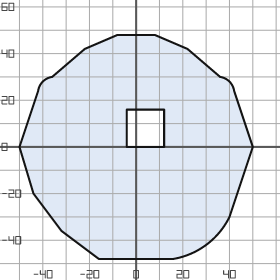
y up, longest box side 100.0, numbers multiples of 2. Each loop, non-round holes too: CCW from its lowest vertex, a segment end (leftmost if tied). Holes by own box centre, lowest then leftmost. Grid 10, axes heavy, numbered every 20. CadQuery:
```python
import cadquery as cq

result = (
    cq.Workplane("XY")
    .moveTo(-16.0, -48.0)
    .lineTo(16.0, -48.0)
    .threePointArc((30.0, -42.0), (40.0, -30.0))
    .lineTo(50.0, 0.0)
    .lineTo(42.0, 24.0)
    .threePointArc((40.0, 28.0), (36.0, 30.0))
    .lineTo(22.0, 42.0)
    .lineTo(8.0, 48.0)
    .lineTo(-8.0, 48.0)
    .lineTo(-22.0, 42.0)
    .lineTo(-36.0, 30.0)
    .threePointArc((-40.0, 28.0), (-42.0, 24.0))
    .lineTo(-50.0, 0.0)
    .lineTo(-44.0, -20.0)
    .lineTo(-32.0, -36.0)
    .close()
    .moveTo(-4.0, 0.0)
    .lineTo(12.0, 0.0)
    .lineTo(12.0, 16.0)
    .lineTo(-4.0, 16.0)
    .close()
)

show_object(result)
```